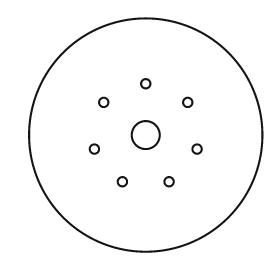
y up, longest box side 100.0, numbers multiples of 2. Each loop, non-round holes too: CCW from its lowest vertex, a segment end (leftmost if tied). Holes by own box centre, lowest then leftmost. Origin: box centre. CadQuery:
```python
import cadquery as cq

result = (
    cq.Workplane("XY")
    .moveTo(0.0, 0.0)
    .circle(50.0)
    .moveTo(-10.0, -20.0)
    .circle(2.0)
    .moveTo(10.0, -20.0)
    .circle(2.0)
    .moveTo(-22.0, -6.0)
    .circle(2.0)
    .moveTo(22.0, -6.0)
    .circle(2.0)
    .moveTo(0.0, 0.0)
    .circle(6.0)
    .moveTo(-18.0, 14.0)
    .circle(2.0)
    .moveTo(18.0, 14.0)
    .circle(2.0)
    .moveTo(0.0, 22.0)
    .circle(2.0)
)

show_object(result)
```